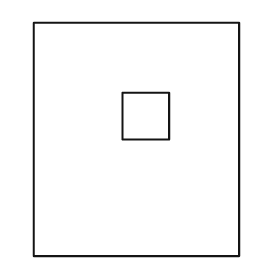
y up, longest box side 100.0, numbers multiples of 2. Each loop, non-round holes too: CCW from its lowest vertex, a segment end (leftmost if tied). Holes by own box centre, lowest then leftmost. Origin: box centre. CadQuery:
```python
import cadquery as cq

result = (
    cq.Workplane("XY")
    .moveTo(-44.0, -50.0)
    .lineTo(44.0, -50.0)
    .lineTo(44.0, 50.0)
    .lineTo(-44.0, 50.0)
    .close()
    .moveTo(-6.0, 0.0)
    .lineTo(14.0, 0.0)
    .lineTo(14.0, 20.0)
    .lineTo(-6.0, 20.0)
    .close()
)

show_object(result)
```